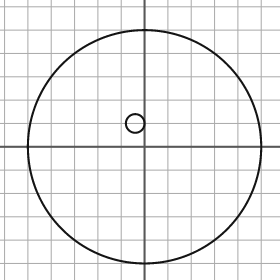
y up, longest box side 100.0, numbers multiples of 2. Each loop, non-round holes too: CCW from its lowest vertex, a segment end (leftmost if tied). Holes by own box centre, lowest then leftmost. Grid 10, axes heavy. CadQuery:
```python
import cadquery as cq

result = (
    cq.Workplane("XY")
    .moveTo(0.0, 0.0)
    .circle(50.0)
    .moveTo(-4.0, 10.0)
    .circle(4.0)
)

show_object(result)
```